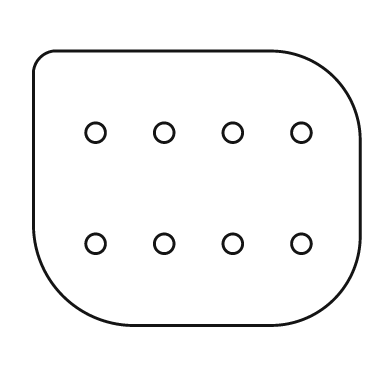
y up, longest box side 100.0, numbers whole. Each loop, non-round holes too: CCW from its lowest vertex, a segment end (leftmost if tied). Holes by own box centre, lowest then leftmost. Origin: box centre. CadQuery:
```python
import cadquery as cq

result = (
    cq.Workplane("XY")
    .moveTo(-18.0, -42.0)
    .lineTo(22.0, -42.0)
    .threePointArc((42.0, -34.0), (50.0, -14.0))
    .lineTo(50.0, 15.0)
    .threePointArc((42.0, 34.0), (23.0, 42.0))
    .lineTo(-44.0, 42.0)
    .threePointArc((-48.0, 40.0), (-50.0, 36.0))
    .lineTo(-50.0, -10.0)
    .threePointArc((-41.0, -33.0), (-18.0, -42.0))
    .close()
    .moveTo(-31.0, -17.0)
    .circle(3.0)
    .moveTo(-10.0, -17.0)
    .circle(3.0)
    .moveTo(11.0, -17.0)
    .circle(3.0)
    .moveTo(32.0, -17.0)
    .circle(3.0)
    .moveTo(-31.0, 17.0)
    .circle(3.0)
    .moveTo(-10.0, 17.0)
    .circle(3.0)
    .moveTo(11.0, 17.0)
    .circle(3.0)
    .moveTo(32.0, 17.0)
    .circle(3.0)
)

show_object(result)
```